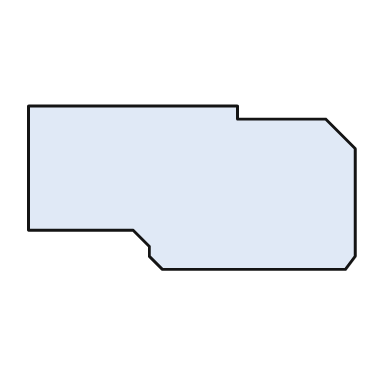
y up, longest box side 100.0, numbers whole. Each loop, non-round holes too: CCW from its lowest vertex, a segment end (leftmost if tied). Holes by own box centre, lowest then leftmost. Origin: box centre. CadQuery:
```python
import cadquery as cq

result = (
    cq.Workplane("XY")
    .moveTo(-9.0, -25.0)
    .lineTo(47.0, -25.0)
    .lineTo(50.0, -21.0)
    .lineTo(50.0, 12.0)
    .lineTo(41.0, 21.0)
    .lineTo(14.0, 21.0)
    .lineTo(14.0, 25.0)
    .lineTo(-50.0, 25.0)
    .lineTo(-50.0, -13.0)
    .lineTo(-18.0, -13.0)
    .lineTo(-13.0, -18.0)
    .lineTo(-13.0, -21.0)
    .close()
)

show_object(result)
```